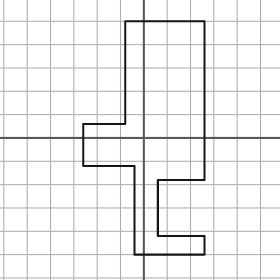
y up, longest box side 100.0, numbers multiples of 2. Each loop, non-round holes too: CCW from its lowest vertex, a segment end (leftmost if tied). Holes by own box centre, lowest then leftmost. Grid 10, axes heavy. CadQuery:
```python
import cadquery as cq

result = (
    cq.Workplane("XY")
    .moveTo(-4.0, -50.0)
    .lineTo(26.0, -50.0)
    .lineTo(26.0, -42.0)
    .lineTo(6.0, -42.0)
    .lineTo(6.0, -18.0)
    .lineTo(26.0, -18.0)
    .lineTo(26.0, 50.0)
    .lineTo(-8.0, 50.0)
    .lineTo(-8.0, 6.0)
    .lineTo(-26.0, 6.0)
    .lineTo(-26.0, -12.0)
    .lineTo(-4.0, -12.0)
    .close()
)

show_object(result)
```